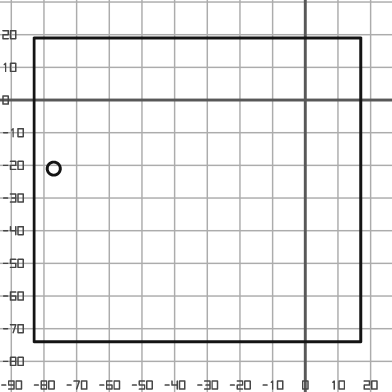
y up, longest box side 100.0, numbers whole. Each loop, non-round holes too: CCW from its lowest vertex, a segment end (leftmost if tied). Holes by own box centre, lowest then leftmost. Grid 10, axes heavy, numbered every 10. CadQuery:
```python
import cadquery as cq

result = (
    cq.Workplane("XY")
    .moveTo(-83.0, -74.0)
    .lineTo(17.0, -74.0)
    .lineTo(17.0, 19.0)
    .lineTo(-83.0, 19.0)
    .close()
    .moveTo(-77.0, -21.0)
    .circle(2.0)
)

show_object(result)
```